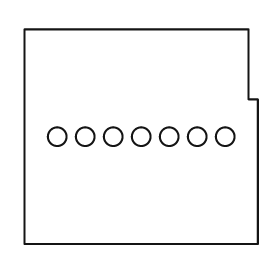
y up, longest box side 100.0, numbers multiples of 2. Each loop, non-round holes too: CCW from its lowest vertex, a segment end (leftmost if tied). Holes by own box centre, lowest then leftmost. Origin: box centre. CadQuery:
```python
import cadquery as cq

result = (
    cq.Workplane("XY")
    .moveTo(-50.0, -46.0)
    .lineTo(50.0, -46.0)
    .lineTo(50.0, 16.0)
    .lineTo(46.0, 16.0)
    .lineTo(46.0, 46.0)
    .lineTo(-50.0, 46.0)
    .close()
    .moveTo(-36.0, 0.0)
    .circle(4.0)
    .moveTo(-24.0, 0.0)
    .circle(4.0)
    .moveTo(-12.0, 0.0)
    .circle(4.0)
    .moveTo(0.0, 0.0)
    .circle(4.0)
    .moveTo(12.0, 0.0)
    .circle(4.0)
    .moveTo(24.0, 0.0)
    .circle(4.0)
    .moveTo(36.0, 0.0)
    .circle(4.0)
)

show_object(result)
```